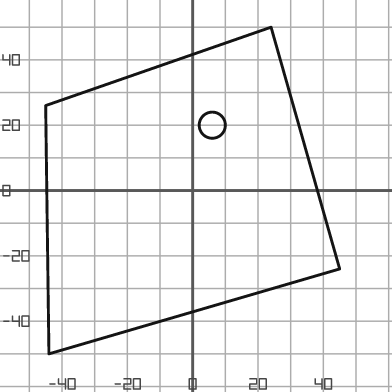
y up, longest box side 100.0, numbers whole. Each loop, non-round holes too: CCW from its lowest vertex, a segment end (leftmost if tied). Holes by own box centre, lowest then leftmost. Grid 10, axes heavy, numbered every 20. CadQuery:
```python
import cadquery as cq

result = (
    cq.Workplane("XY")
    .moveTo(-44.0, -50.0)
    .lineTo(45.0, -24.0)
    .lineTo(24.0, 50.0)
    .lineTo(-45.0, 26.0)
    .close()
    .moveTo(6.0, 20.0)
    .circle(4.0)
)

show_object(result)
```